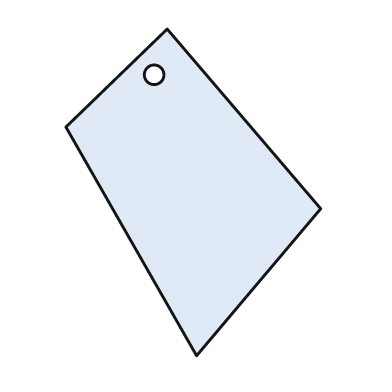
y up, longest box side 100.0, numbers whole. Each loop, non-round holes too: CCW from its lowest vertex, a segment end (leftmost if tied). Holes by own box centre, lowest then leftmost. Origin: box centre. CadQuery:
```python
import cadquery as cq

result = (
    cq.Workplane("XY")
    .moveTo(1.0, -50.0)
    .lineTo(39.0, -5.0)
    .lineTo(-8.0, 50.0)
    .lineTo(-39.0, 20.0)
    .close()
    .moveTo(-12.0, 36.0)
    .circle(3.0)
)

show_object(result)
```